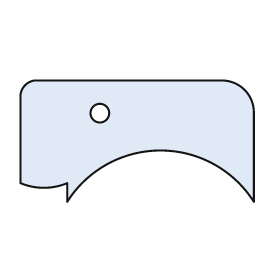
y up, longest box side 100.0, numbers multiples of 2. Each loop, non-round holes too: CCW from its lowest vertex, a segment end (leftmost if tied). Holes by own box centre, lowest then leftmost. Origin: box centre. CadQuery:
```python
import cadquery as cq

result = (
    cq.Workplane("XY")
    .moveTo(-30.0, -26.0)
    .threePointArc((10.0, -4.0), (50.0, -26.0))
    .lineTo(50.0, 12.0)
    .threePointArc((46.0, 22.0), (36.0, 26.0))
    .lineTo(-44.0, 26.0)
    .threePointArc((-48.0, 24.0), (-50.0, 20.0))
    .lineTo(-50.0, -18.0)
    .threePointArc((-40.0, -20.0), (-30.0, -18.0))
    .close()
    .moveTo(-16.0, 12.0)
    .circle(4.0)
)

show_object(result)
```